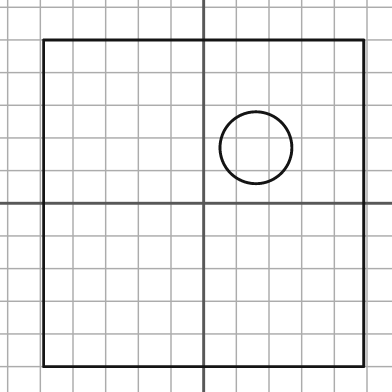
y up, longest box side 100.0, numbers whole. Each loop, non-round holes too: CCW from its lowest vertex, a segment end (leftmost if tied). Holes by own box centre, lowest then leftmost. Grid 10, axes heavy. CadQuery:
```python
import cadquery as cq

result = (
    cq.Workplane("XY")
    .moveTo(-49.0, -50.0)
    .lineTo(49.0, -50.0)
    .lineTo(49.0, 50.0)
    .lineTo(-49.0, 50.0)
    .close()
    .moveTo(16.0, 17.0)
    .circle(11.0)
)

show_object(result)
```